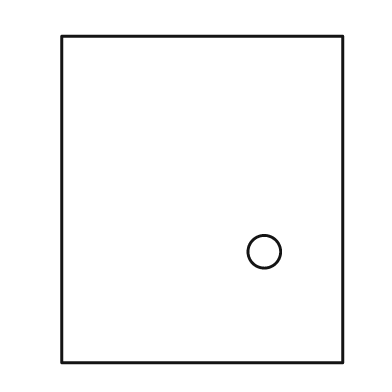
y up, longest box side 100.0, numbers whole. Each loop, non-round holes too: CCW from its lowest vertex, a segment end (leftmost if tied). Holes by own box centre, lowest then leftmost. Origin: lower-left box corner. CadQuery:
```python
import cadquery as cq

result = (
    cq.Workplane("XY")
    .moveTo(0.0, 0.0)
    .lineTo(86.0, 0.0)
    .lineTo(86.0, 100.0)
    .lineTo(0.0, 100.0)
    .close()
    .moveTo(62.0, 34.0)
    .circle(5.0)
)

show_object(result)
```